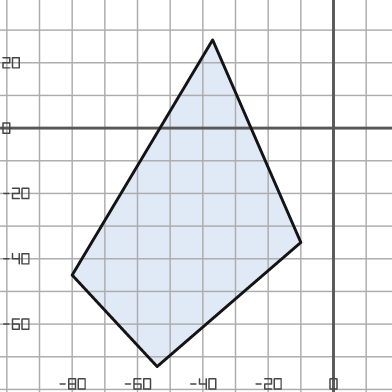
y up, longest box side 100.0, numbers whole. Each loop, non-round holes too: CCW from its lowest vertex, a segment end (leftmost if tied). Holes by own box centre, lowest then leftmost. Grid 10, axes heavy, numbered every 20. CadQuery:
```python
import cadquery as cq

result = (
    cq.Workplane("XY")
    .moveTo(-54.0, -73.0)
    .lineTo(-10.0, -35.0)
    .lineTo(-37.0, 27.0)
    .lineTo(-80.0, -45.0)
    .close()
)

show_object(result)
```